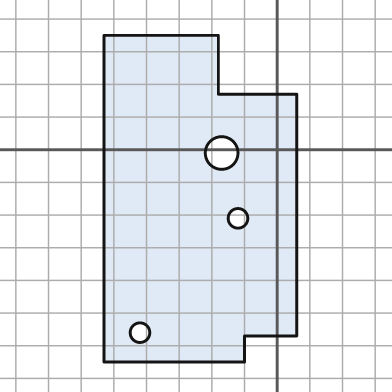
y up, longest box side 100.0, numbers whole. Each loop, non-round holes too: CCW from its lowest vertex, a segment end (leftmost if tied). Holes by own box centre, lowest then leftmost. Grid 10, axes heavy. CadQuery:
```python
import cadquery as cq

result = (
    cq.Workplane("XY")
    .moveTo(-53.0, -65.0)
    .lineTo(-10.0, -65.0)
    .lineTo(-10.0, -57.0)
    .lineTo(6.0, -57.0)
    .lineTo(6.0, 17.0)
    .lineTo(-18.0, 17.0)
    .lineTo(-18.0, 35.0)
    .lineTo(-53.0, 35.0)
    .close()
    .moveTo(-42.0, -56.0)
    .circle(3.0)
    .moveTo(-12.0, -21.0)
    .circle(3.0)
    .moveTo(-17.0, -1.0)
    .circle(5.0)
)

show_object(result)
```